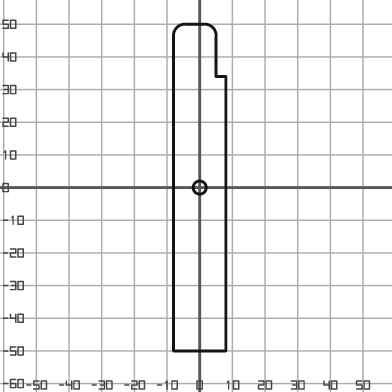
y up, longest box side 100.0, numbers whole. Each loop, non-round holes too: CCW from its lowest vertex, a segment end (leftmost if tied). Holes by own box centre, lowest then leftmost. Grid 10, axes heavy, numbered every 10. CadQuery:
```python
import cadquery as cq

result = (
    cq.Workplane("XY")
    .moveTo(-8.0, -50.0)
    .lineTo(8.0, -50.0)
    .lineTo(8.0, 34.0)
    .lineTo(5.0, 34.0)
    .lineTo(5.0, 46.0)
    .threePointArc((4.0, 49.0), (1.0, 50.0))
    .lineTo(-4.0, 50.0)
    .threePointArc((-7.0, 49.0), (-8.0, 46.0))
    .close()
    .moveTo(0.0, 0.0)
    .circle(2.0)
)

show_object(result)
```